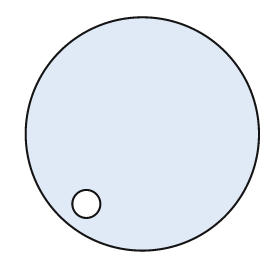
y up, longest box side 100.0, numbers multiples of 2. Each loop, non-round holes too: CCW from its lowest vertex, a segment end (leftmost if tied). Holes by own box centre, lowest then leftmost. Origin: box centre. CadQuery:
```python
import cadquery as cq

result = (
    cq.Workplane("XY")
    .moveTo(0.0, 0.0)
    .circle(50.0)
    .moveTo(-24.0, -30.0)
    .circle(6.0)
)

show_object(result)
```